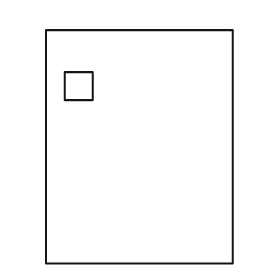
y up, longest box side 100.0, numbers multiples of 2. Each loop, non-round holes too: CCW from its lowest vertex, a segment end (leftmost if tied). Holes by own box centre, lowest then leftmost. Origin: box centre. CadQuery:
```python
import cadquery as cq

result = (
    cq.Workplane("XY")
    .moveTo(-40.0, -50.0)
    .lineTo(40.0, -50.0)
    .lineTo(40.0, 50.0)
    .lineTo(-40.0, 50.0)
    .close()
    .moveTo(-32.0, 20.0)
    .lineTo(-20.0, 20.0)
    .lineTo(-20.0, 32.0)
    .lineTo(-32.0, 32.0)
    .close()
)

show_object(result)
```